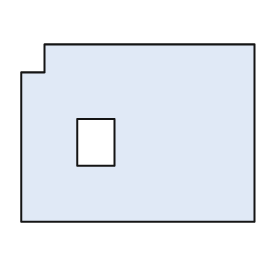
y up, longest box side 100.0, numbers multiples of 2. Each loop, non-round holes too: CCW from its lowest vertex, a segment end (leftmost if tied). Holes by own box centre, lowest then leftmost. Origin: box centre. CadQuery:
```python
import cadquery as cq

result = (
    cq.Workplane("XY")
    .moveTo(-50.0, -38.0)
    .lineTo(50.0, -38.0)
    .lineTo(50.0, 38.0)
    .lineTo(-40.0, 38.0)
    .lineTo(-40.0, 26.0)
    .lineTo(-50.0, 26.0)
    .close()
    .moveTo(-26.0, -14.0)
    .lineTo(-10.0, -14.0)
    .lineTo(-10.0, 6.0)
    .lineTo(-26.0, 6.0)
    .close()
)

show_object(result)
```